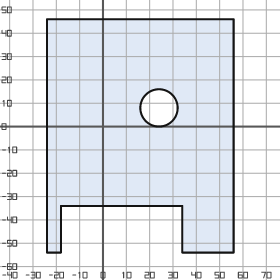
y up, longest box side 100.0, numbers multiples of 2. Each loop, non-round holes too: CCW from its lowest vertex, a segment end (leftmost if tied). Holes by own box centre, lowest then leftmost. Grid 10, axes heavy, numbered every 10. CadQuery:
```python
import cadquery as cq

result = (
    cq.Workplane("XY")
    .moveTo(-24.0, -54.0)
    .lineTo(-18.0, -54.0)
    .lineTo(-18.0, -34.0)
    .lineTo(34.0, -34.0)
    .lineTo(34.0, -54.0)
    .lineTo(56.0, -54.0)
    .lineTo(56.0, 46.0)
    .lineTo(-24.0, 46.0)
    .close()
    .moveTo(24.0, 8.0)
    .circle(8.0)
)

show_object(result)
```